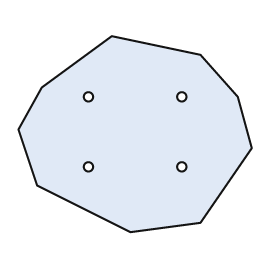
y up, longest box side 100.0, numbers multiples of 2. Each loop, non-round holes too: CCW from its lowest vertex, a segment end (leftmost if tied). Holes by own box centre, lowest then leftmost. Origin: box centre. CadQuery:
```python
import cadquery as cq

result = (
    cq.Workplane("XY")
    .moveTo(-2.0, -42.0)
    .lineTo(28.0, -38.0)
    .lineTo(50.0, -6.0)
    .lineTo(44.0, 16.0)
    .lineTo(28.0, 34.0)
    .lineTo(-10.0, 42.0)
    .lineTo(-40.0, 20.0)
    .lineTo(-50.0, 2.0)
    .lineTo(-42.0, -22.0)
    .close()
    .moveTo(-20.0, -14.0)
    .circle(2.0)
    .moveTo(20.0, -14.0)
    .circle(2.0)
    .moveTo(-20.0, 16.0)
    .circle(2.0)
    .moveTo(20.0, 16.0)
    .circle(2.0)
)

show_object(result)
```